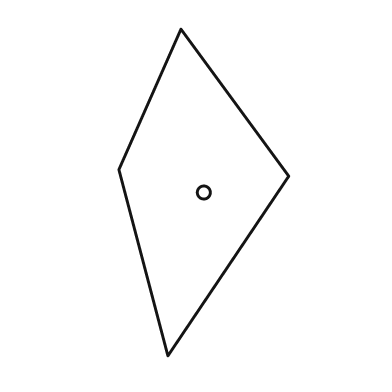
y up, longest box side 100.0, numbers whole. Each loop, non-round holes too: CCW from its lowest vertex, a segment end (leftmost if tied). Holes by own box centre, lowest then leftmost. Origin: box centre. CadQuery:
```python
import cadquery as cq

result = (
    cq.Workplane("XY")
    .moveTo(-11.0, -50.0)
    .lineTo(26.0, 5.0)
    .lineTo(-7.0, 50.0)
    .lineTo(-26.0, 7.0)
    .close()
    .moveTo(0.0, 0.0)
    .circle(2.0)
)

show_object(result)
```